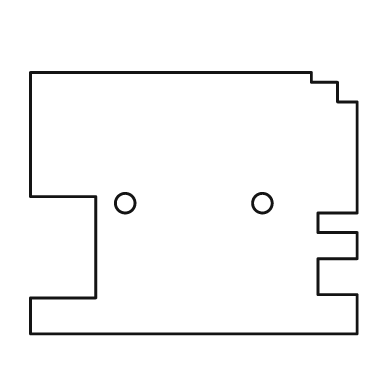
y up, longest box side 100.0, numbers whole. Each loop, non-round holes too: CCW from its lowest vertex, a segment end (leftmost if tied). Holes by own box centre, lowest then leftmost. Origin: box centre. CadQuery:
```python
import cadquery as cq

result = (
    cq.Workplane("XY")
    .moveTo(-50.0, -40.0)
    .lineTo(50.0, -40.0)
    .lineTo(50.0, -28.0)
    .lineTo(38.0, -28.0)
    .lineTo(38.0, -17.0)
    .lineTo(50.0, -17.0)
    .lineTo(50.0, -9.0)
    .lineTo(38.0, -9.0)
    .lineTo(38.0, -3.0)
    .lineTo(50.0, -3.0)
    .lineTo(50.0, 31.0)
    .lineTo(44.0, 31.0)
    .lineTo(44.0, 37.0)
    .lineTo(36.0, 37.0)
    .lineTo(36.0, 40.0)
    .lineTo(-50.0, 40.0)
    .lineTo(-50.0, 2.0)
    .lineTo(-30.0, 2.0)
    .lineTo(-30.0, -29.0)
    .lineTo(-50.0, -29.0)
    .close()
    .moveTo(-21.0, 0.0)
    .circle(3.0)
    .moveTo(21.0, 0.0)
    .circle(3.0)
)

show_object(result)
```